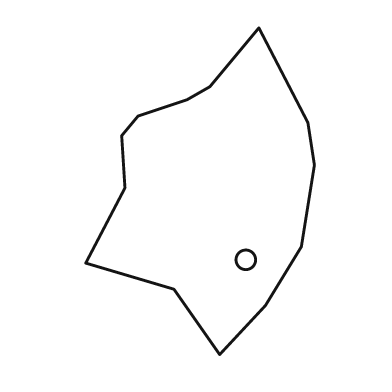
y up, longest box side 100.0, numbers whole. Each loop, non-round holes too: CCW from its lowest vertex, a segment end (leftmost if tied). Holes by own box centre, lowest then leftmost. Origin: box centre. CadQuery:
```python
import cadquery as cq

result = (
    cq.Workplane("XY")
    .moveTo(6.0, -50.0)
    .lineTo(20.0, -35.0)
    .lineTo(31.0, -17.0)
    .lineTo(35.0, 8.0)
    .lineTo(33.0, 21.0)
    .lineTo(18.0, 50.0)
    .lineTo(3.0, 32.0)
    .lineTo(-4.0, 28.0)
    .lineTo(-19.0, 23.0)
    .lineTo(-24.0, 17.0)
    .lineTo(-23.0, 1.0)
    .lineTo(-35.0, -22.0)
    .lineTo(-8.0, -30.0)
    .close()
    .moveTo(14.0, -21.0)
    .circle(3.0)
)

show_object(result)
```